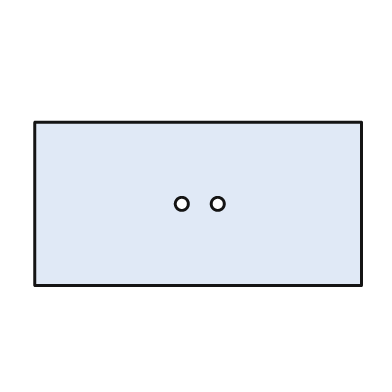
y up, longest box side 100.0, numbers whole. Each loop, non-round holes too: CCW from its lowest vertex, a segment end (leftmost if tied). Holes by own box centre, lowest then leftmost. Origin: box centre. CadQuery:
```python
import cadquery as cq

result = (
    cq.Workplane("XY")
    .moveTo(-50.0, -25.0)
    .lineTo(50.0, -25.0)
    .lineTo(50.0, 25.0)
    .lineTo(-50.0, 25.0)
    .close()
    .moveTo(-5.0, 0.0)
    .circle(2.0)
    .moveTo(6.0, 0.0)
    .circle(2.0)
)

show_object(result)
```